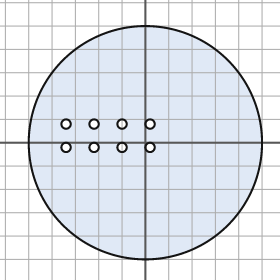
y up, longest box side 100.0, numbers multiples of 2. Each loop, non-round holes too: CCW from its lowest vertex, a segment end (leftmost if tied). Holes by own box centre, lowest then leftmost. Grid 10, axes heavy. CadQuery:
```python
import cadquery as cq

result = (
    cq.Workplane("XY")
    .moveTo(0.0, 0.0)
    .circle(50.0)
    .moveTo(-34.0, -2.0)
    .circle(2.0)
    .moveTo(-22.0, -2.0)
    .circle(2.0)
    .moveTo(-10.0, -2.0)
    .circle(2.0)
    .moveTo(2.0, -2.0)
    .circle(2.0)
    .moveTo(-34.0, 8.0)
    .circle(2.0)
    .moveTo(-22.0, 8.0)
    .circle(2.0)
    .moveTo(-10.0, 8.0)
    .circle(2.0)
    .moveTo(2.0, 8.0)
    .circle(2.0)
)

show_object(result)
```